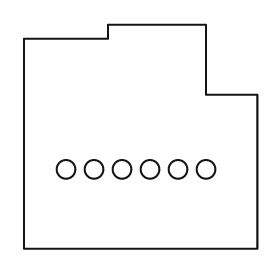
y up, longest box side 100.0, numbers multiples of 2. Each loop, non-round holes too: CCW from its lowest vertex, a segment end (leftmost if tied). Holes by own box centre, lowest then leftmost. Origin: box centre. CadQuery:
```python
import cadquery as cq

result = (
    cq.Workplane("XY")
    .moveTo(-50.0, -48.0)
    .lineTo(50.0, -48.0)
    .lineTo(50.0, 18.0)
    .lineTo(28.0, 18.0)
    .lineTo(28.0, 48.0)
    .lineTo(-14.0, 48.0)
    .lineTo(-14.0, 42.0)
    .lineTo(-50.0, 42.0)
    .close()
    .moveTo(-32.0, -14.0)
    .circle(4.0)
    .moveTo(-20.0, -14.0)
    .circle(4.0)
    .moveTo(-8.0, -14.0)
    .circle(4.0)
    .moveTo(4.0, -14.0)
    .circle(4.0)
    .moveTo(16.0, -14.0)
    .circle(4.0)
    .moveTo(28.0, -14.0)
    .circle(4.0)
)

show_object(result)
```